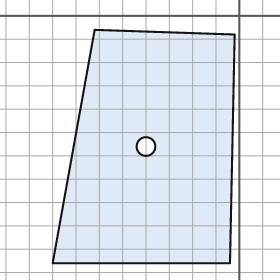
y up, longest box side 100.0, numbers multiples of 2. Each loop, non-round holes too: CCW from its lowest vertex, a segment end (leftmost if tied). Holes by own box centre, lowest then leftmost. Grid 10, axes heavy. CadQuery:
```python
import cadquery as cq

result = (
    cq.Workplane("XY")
    .moveTo(-80.0, -106.0)
    .lineTo(-4.0, -106.0)
    .lineTo(-2.0, -8.0)
    .lineTo(-62.0, -6.0)
    .close()
    .moveTo(-40.0, -56.0)
    .circle(4.0)
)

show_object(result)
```